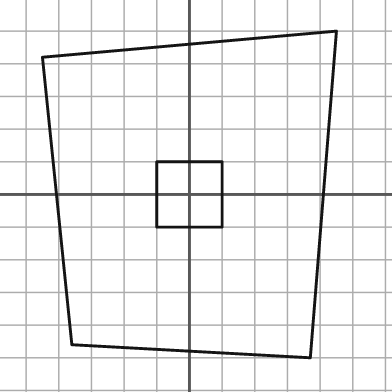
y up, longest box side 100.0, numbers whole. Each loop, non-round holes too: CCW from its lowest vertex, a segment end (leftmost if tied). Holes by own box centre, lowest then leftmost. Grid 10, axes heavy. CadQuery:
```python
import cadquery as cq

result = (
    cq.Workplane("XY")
    .moveTo(37.0, -50.0)
    .lineTo(45.0, 50.0)
    .lineTo(-45.0, 42.0)
    .lineTo(-36.0, -46.0)
    .close()
    .moveTo(-10.0, -10.0)
    .lineTo(10.0, -10.0)
    .lineTo(10.0, 10.0)
    .lineTo(-10.0, 10.0)
    .close()
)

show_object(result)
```